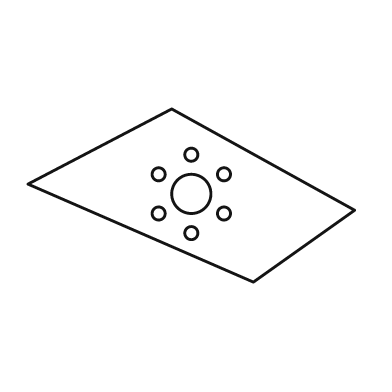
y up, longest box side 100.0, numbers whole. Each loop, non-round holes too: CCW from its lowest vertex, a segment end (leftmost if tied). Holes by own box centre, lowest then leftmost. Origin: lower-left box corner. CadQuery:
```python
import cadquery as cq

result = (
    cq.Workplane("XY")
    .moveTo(69.0, 0.0)
    .lineTo(100.0, 22.0)
    .lineTo(44.0, 53.0)
    .lineTo(0.0, 30.0)
    .close()
    .moveTo(50.0, 15.0)
    .circle(2.0)
    .moveTo(40.0, 21.0)
    .circle(2.0)
    .moveTo(60.0, 21.0)
    .circle(2.0)
    .moveTo(50.0, 27.0)
    .circle(6.0)
    .moveTo(40.0, 33.0)
    .circle(2.0)
    .moveTo(60.0, 33.0)
    .circle(2.0)
    .moveTo(50.0, 39.0)
    .circle(2.0)
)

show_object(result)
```